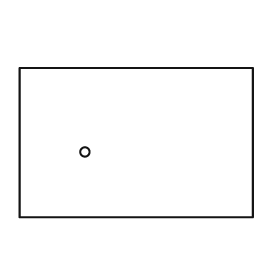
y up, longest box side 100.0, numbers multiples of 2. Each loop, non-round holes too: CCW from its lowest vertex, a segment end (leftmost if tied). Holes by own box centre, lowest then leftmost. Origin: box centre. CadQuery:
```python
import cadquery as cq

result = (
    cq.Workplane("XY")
    .moveTo(-50.0, -32.0)
    .lineTo(50.0, -32.0)
    .lineTo(50.0, 32.0)
    .lineTo(-50.0, 32.0)
    .close()
    .moveTo(-22.0, -4.0)
    .circle(2.0)
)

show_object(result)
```